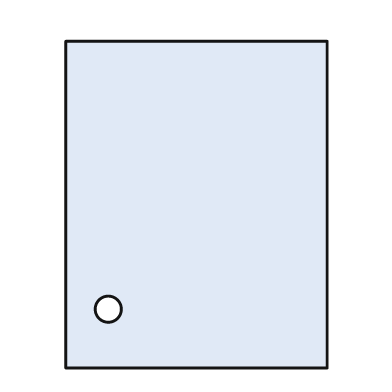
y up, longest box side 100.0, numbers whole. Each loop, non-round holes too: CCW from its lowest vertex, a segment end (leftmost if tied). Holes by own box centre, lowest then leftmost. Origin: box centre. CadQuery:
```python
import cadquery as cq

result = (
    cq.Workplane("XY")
    .moveTo(-40.0, -50.0)
    .lineTo(40.0, -50.0)
    .lineTo(40.0, 50.0)
    .lineTo(-40.0, 50.0)
    .close()
    .moveTo(-27.0, -32.0)
    .circle(4.0)
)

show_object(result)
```